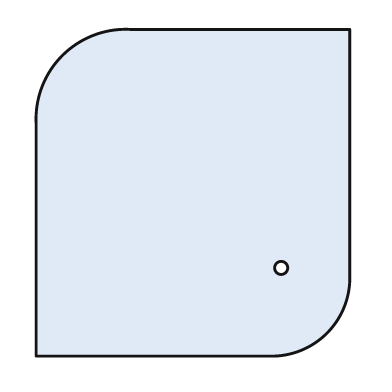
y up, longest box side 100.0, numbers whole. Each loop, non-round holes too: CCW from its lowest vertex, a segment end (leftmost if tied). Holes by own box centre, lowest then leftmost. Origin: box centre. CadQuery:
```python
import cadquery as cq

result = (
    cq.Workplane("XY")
    .moveTo(-48.0, -50.0)
    .lineTo(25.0, -50.0)
    .threePointArc((41.0, -43.0), (48.0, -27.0))
    .lineTo(48.0, 50.0)
    .lineTo(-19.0, 50.0)
    .threePointArc((-40.0, 42.0), (-48.0, 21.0))
    .close()
    .moveTo(27.0, -23.0)
    .circle(2.0)
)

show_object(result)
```